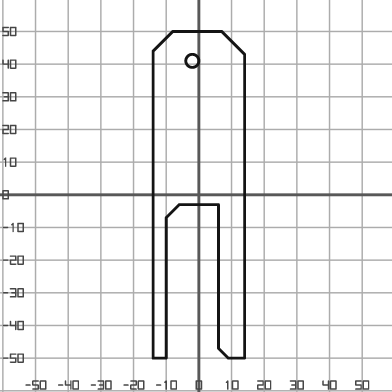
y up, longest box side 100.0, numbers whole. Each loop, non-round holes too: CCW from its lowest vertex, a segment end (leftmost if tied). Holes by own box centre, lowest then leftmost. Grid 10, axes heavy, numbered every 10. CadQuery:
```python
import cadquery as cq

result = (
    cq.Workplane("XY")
    .moveTo(-14.0, -50.0)
    .lineTo(-10.0, -50.0)
    .lineTo(-10.0, -7.0)
    .lineTo(-6.0, -3.0)
    .lineTo(6.0, -3.0)
    .lineTo(6.0, -47.0)
    .lineTo(9.0, -50.0)
    .lineTo(14.0, -50.0)
    .lineTo(14.0, 43.0)
    .lineTo(7.0, 50.0)
    .lineTo(-8.0, 50.0)
    .lineTo(-14.0, 44.0)
    .close()
    .moveTo(-2.0, 41.0)
    .circle(2.0)
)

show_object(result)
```